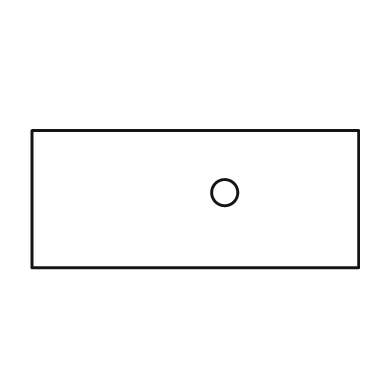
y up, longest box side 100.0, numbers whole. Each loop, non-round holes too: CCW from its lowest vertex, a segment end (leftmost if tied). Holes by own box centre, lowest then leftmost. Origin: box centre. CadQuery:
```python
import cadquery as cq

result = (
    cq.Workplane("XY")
    .moveTo(-50.0, -21.0)
    .lineTo(50.0, -21.0)
    .lineTo(50.0, 21.0)
    .lineTo(-50.0, 21.0)
    .close()
    .moveTo(9.0, 2.0)
    .circle(4.0)
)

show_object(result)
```